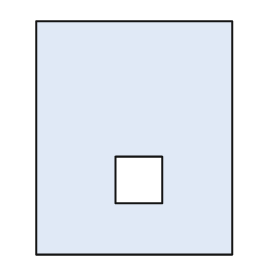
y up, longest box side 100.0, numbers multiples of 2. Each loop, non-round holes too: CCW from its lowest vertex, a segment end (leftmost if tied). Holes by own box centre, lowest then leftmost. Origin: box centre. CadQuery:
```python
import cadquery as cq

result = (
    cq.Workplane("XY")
    .moveTo(-42.0, -50.0)
    .lineTo(42.0, -50.0)
    .lineTo(42.0, 50.0)
    .lineTo(-42.0, 50.0)
    .close()
    .moveTo(-8.0, -28.0)
    .lineTo(12.0, -28.0)
    .lineTo(12.0, -8.0)
    .lineTo(-8.0, -8.0)
    .close()
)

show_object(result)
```